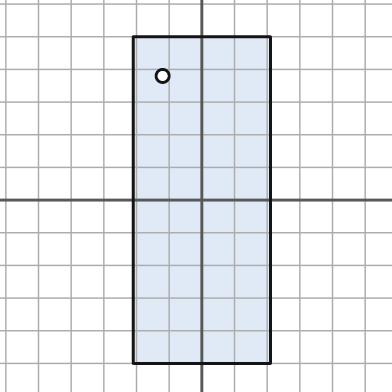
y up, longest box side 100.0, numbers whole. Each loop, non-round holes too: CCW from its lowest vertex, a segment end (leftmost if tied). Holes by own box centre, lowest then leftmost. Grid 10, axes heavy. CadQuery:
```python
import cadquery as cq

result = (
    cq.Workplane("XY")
    .moveTo(-21.0, -50.0)
    .lineTo(21.0, -50.0)
    .lineTo(21.0, 50.0)
    .lineTo(-21.0, 50.0)
    .close()
    .moveTo(-12.0, 38.0)
    .circle(2.0)
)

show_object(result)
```